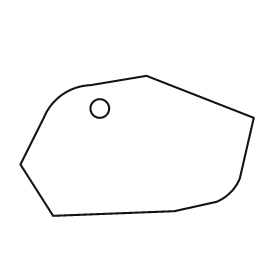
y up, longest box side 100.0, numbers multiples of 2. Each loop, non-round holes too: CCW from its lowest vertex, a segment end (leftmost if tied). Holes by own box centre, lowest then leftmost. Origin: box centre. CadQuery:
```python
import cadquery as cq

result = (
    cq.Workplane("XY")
    .moveTo(-36.0, -30.0)
    .lineTo(16.0, -28.0)
    .lineTo(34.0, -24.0)
    .threePointArc((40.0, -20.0), (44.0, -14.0))
    .lineTo(50.0, 12.0)
    .lineTo(4.0, 30.0)
    .lineTo(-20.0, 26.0)
    .threePointArc((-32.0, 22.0), (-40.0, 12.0))
    .lineTo(-50.0, -8.0)
    .close()
    .moveTo(-16.0, 16.0)
    .circle(4.0)
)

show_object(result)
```